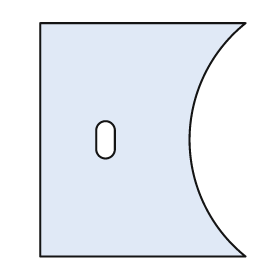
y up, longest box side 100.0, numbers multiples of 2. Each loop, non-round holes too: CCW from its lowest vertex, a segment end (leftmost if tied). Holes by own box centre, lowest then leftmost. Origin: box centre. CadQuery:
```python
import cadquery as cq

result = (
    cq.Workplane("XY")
    .moveTo(-44.0, -50.0)
    .lineTo(44.0, -50.0)
    .threePointArc((20.0, 0.0), (44.0, 50.0))
    .lineTo(-44.0, 50.0)
    .close()
    .moveTo(-20.0, -4.0)
    .threePointArc((-16.0, -8.0), (-12.0, -4.0))
    .lineTo(-12.0, 4.0)
    .threePointArc((-16.0, 8.0), (-20.0, 4.0))
    .close()
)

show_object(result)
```